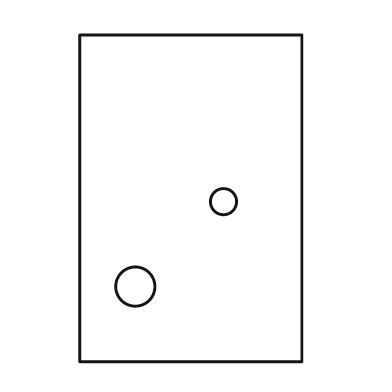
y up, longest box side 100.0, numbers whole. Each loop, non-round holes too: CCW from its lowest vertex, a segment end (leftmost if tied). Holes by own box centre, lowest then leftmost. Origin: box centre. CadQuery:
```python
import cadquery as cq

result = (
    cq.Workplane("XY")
    .moveTo(-34.0, -50.0)
    .lineTo(34.0, -50.0)
    .lineTo(34.0, 50.0)
    .lineTo(-34.0, 50.0)
    .close()
    .moveTo(-17.0, -27.0)
    .circle(6.0)
    .moveTo(10.0, -1.0)
    .circle(4.0)
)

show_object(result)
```